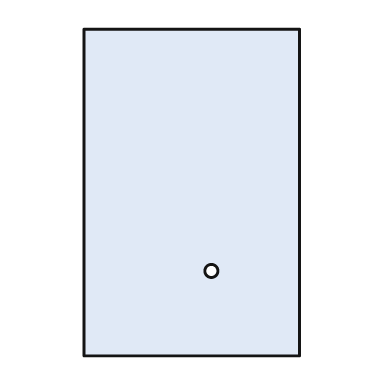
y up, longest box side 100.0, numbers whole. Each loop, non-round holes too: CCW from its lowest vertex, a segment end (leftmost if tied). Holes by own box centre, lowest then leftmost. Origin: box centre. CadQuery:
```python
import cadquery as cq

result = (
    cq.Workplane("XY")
    .moveTo(-33.0, -50.0)
    .lineTo(33.0, -50.0)
    .lineTo(33.0, 50.0)
    .lineTo(-33.0, 50.0)
    .close()
    .moveTo(6.0, -24.0)
    .circle(2.0)
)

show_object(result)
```